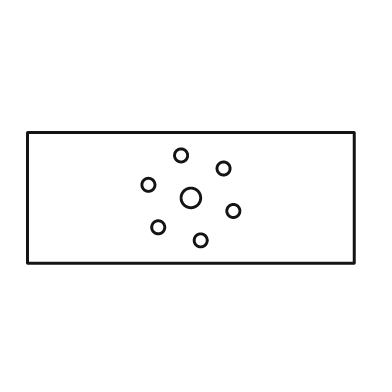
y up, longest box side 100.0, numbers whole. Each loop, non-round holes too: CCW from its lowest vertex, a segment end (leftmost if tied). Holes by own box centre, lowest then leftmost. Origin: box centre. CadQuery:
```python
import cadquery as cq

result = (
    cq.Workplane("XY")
    .moveTo(-50.0, -20.0)
    .lineTo(50.0, -20.0)
    .lineTo(50.0, 20.0)
    .lineTo(-50.0, 20.0)
    .close()
    .moveTo(3.0, -13.0)
    .circle(2.0)
    .moveTo(-10.0, -9.0)
    .circle(2.0)
    .moveTo(13.0, -4.0)
    .circle(2.0)
    .moveTo(0.0, 0.0)
    .circle(3.0)
    .moveTo(-13.0, 4.0)
    .circle(2.0)
    .moveTo(10.0, 9.0)
    .circle(2.0)
    .moveTo(-3.0, 13.0)
    .circle(2.0)
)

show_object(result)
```